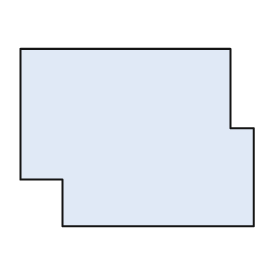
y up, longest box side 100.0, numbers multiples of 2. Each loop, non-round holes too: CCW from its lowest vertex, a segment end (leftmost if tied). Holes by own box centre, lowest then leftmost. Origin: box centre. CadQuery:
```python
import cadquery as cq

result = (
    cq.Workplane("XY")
    .moveTo(-32.0, -38.0)
    .lineTo(50.0, -38.0)
    .lineTo(50.0, 4.0)
    .lineTo(40.0, 4.0)
    .lineTo(40.0, 38.0)
    .lineTo(-50.0, 38.0)
    .lineTo(-50.0, -18.0)
    .lineTo(-32.0, -18.0)
    .close()
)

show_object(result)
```